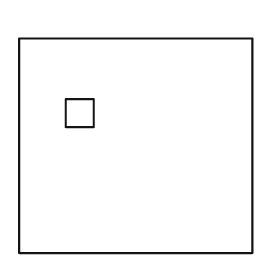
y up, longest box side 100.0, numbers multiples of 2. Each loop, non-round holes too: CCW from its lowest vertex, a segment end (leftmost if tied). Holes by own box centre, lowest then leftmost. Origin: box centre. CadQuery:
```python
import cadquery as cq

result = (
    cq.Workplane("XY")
    .moveTo(-50.0, -46.0)
    .lineTo(50.0, -46.0)
    .lineTo(50.0, 46.0)
    .lineTo(-50.0, 46.0)
    .close()
    .moveTo(-30.0, 8.0)
    .lineTo(-18.0, 8.0)
    .lineTo(-18.0, 20.0)
    .lineTo(-30.0, 20.0)
    .close()
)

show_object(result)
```